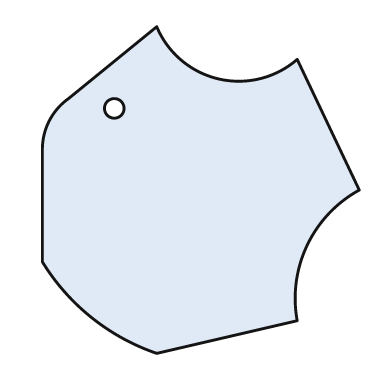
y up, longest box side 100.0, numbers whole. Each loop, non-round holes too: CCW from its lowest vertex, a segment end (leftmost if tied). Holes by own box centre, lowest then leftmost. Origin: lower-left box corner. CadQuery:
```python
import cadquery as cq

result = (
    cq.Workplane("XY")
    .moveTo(35.0, 0.0)
    .lineTo(78.0, 10.0)
    .threePointArc((81.0, 33.0), (97.0, 50.0))
    .lineTo(78.0, 90.0)
    .threePointArc((54.0, 84.0), (35.0, 100.0))
    .lineTo(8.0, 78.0)
    .threePointArc((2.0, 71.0), (0.0, 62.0))
    .lineTo(0.0, 28.0)
    .threePointArc((15.0, 11.0), (35.0, 0.0))
    .close()
    .moveTo(22.0, 75.0)
    .circle(3.0)
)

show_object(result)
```